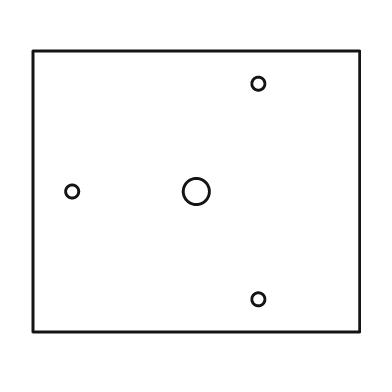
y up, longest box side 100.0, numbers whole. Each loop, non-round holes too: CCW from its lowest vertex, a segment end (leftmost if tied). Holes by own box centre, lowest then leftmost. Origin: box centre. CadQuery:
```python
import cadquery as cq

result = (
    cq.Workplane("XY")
    .moveTo(-50.0, -43.0)
    .lineTo(50.0, -43.0)
    .lineTo(50.0, 43.0)
    .lineTo(-50.0, 43.0)
    .close()
    .moveTo(19.0, -33.0)
    .circle(2.0)
    .moveTo(-38.0, 0.0)
    .circle(2.0)
    .moveTo(0.0, 0.0)
    .circle(4.0)
    .moveTo(19.0, 33.0)
    .circle(2.0)
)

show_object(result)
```